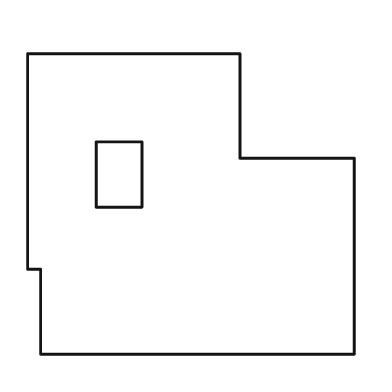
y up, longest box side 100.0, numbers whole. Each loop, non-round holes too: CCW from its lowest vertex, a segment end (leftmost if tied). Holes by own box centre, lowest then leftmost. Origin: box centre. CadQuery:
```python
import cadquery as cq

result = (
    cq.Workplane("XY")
    .moveTo(-46.0, -46.0)
    .lineTo(50.0, -46.0)
    .lineTo(50.0, 14.0)
    .lineTo(15.0, 14.0)
    .lineTo(15.0, 46.0)
    .lineTo(-50.0, 46.0)
    .lineTo(-50.0, -20.0)
    .lineTo(-46.0, -20.0)
    .close()
    .moveTo(-29.0, -1.0)
    .lineTo(-15.0, -1.0)
    .lineTo(-15.0, 19.0)
    .lineTo(-29.0, 19.0)
    .close()
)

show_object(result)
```